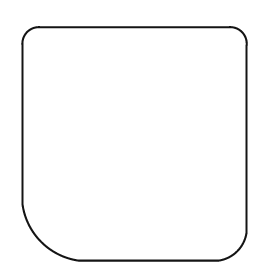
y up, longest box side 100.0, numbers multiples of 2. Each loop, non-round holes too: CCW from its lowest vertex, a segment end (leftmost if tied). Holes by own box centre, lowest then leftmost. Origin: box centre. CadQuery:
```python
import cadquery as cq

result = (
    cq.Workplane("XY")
    .moveTo(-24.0, -50.0)
    .lineTo(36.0, -50.0)
    .threePointArc((44.0, -46.0), (48.0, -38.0))
    .lineTo(48.0, 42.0)
    .threePointArc((46.0, 48.0), (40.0, 50.0))
    .lineTo(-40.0, 50.0)
    .threePointArc((-46.0, 48.0), (-48.0, 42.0))
    .lineTo(-48.0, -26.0)
    .threePointArc((-40.0, -42.0), (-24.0, -50.0))
    .close()
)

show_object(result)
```